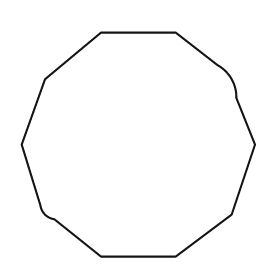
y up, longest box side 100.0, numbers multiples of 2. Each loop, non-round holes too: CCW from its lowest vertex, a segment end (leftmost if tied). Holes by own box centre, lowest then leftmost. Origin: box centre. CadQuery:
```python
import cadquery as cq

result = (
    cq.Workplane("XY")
    .moveTo(-16.0, -48.0)
    .lineTo(16.0, -48.0)
    .lineTo(40.0, -30.0)
    .lineTo(50.0, 0.0)
    .lineTo(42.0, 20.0)
    .threePointArc((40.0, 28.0), (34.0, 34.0))
    .lineTo(16.0, 48.0)
    .lineTo(-16.0, 48.0)
    .lineTo(-40.0, 28.0)
    .lineTo(-50.0, 0.0)
    .lineTo(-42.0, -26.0)
    .threePointArc((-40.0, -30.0), (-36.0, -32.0))
    .close()
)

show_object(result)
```